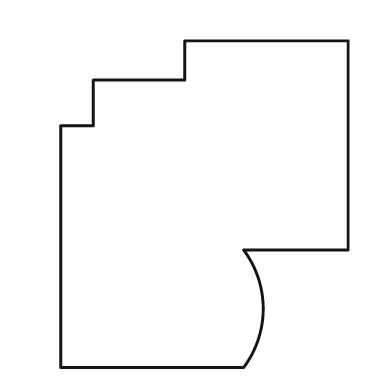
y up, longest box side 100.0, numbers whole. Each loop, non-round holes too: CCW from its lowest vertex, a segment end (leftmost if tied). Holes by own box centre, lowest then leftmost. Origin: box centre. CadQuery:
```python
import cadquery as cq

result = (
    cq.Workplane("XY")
    .moveTo(-44.0, -50.0)
    .lineTo(12.0, -50.0)
    .threePointArc((18.0, -32.0), (12.0, -14.0))
    .lineTo(44.0, -14.0)
    .lineTo(44.0, 50.0)
    .lineTo(-6.0, 50.0)
    .lineTo(-6.0, 38.0)
    .lineTo(-34.0, 38.0)
    .lineTo(-34.0, 24.0)
    .lineTo(-44.0, 24.0)
    .close()
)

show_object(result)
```